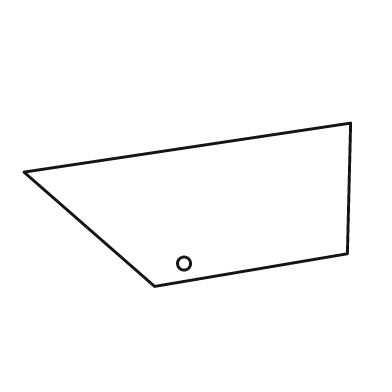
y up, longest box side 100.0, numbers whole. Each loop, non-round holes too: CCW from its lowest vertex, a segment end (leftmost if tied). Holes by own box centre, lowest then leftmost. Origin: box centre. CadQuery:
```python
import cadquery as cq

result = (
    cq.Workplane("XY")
    .moveTo(-10.0, -25.0)
    .lineTo(49.0, -15.0)
    .lineTo(50.0, 25.0)
    .lineTo(-50.0, 10.0)
    .close()
    .moveTo(-1.0, -18.0)
    .circle(2.0)
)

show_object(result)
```